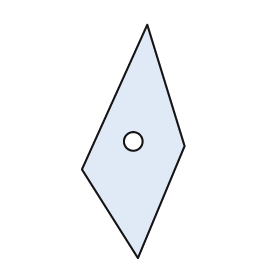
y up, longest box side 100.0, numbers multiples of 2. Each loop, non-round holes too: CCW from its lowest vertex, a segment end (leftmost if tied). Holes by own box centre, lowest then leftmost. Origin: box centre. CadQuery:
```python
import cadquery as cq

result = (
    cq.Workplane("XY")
    .moveTo(2.0, -50.0)
    .lineTo(22.0, -2.0)
    .lineTo(6.0, 50.0)
    .lineTo(-22.0, -12.0)
    .close()
    .moveTo(0.0, 0.0)
    .circle(4.0)
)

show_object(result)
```